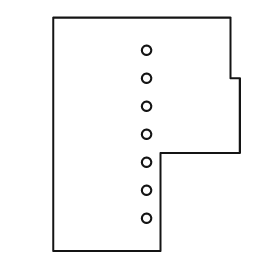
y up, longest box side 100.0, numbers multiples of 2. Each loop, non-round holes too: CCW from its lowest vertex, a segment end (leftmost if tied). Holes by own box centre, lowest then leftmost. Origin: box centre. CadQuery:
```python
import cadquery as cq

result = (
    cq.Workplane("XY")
    .moveTo(-40.0, -50.0)
    .lineTo(6.0, -50.0)
    .lineTo(6.0, -8.0)
    .lineTo(40.0, -8.0)
    .lineTo(40.0, 24.0)
    .lineTo(36.0, 24.0)
    .lineTo(36.0, 50.0)
    .lineTo(-40.0, 50.0)
    .close()
    .moveTo(0.0, -36.0)
    .circle(2.0)
    .moveTo(0.0, -24.0)
    .circle(2.0)
    .moveTo(0.0, -12.0)
    .circle(2.0)
    .moveTo(0.0, 0.0)
    .circle(2.0)
    .moveTo(0.0, 12.0)
    .circle(2.0)
    .moveTo(0.0, 24.0)
    .circle(2.0)
    .moveTo(0.0, 36.0)
    .circle(2.0)
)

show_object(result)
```